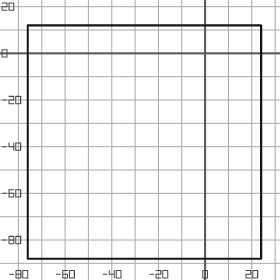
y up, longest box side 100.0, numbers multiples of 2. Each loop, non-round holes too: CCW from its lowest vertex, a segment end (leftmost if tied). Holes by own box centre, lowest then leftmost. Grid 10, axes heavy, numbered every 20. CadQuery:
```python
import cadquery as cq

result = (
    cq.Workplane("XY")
    .moveTo(-76.0, -88.0)
    .lineTo(24.0, -88.0)
    .lineTo(24.0, 12.0)
    .lineTo(-76.0, 12.0)
    .close()
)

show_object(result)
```